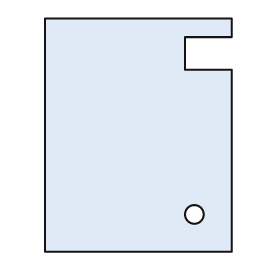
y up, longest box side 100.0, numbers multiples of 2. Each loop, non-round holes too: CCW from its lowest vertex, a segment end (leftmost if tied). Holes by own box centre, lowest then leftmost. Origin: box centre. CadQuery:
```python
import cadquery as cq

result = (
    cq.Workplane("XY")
    .moveTo(-40.0, -50.0)
    .lineTo(40.0, -50.0)
    .lineTo(40.0, 28.0)
    .lineTo(20.0, 28.0)
    .lineTo(20.0, 42.0)
    .lineTo(40.0, 42.0)
    .lineTo(40.0, 50.0)
    .lineTo(-40.0, 50.0)
    .close()
    .moveTo(24.0, -34.0)
    .circle(4.0)
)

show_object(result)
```